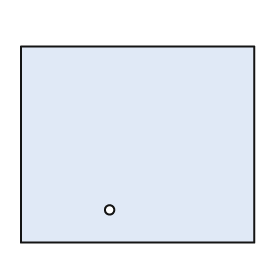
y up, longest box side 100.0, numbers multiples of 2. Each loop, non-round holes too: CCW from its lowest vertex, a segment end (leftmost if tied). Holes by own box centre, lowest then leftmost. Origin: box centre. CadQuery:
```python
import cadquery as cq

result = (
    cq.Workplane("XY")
    .moveTo(-50.0, -42.0)
    .lineTo(50.0, -42.0)
    .lineTo(50.0, 42.0)
    .lineTo(-50.0, 42.0)
    .close()
    .moveTo(-12.0, -28.0)
    .circle(2.0)
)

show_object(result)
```